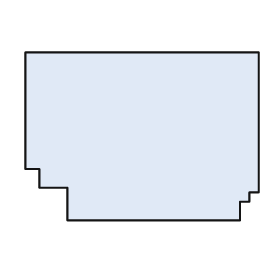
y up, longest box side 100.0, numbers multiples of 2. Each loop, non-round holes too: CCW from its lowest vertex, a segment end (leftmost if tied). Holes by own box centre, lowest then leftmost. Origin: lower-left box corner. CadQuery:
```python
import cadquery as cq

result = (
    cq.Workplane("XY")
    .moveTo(18.0, 0.0)
    .lineTo(92.0, 0.0)
    .lineTo(92.0, 8.0)
    .lineTo(96.0, 8.0)
    .lineTo(96.0, 12.0)
    .lineTo(100.0, 12.0)
    .lineTo(100.0, 72.0)
    .lineTo(0.0, 72.0)
    .lineTo(0.0, 22.0)
    .lineTo(6.0, 22.0)
    .lineTo(6.0, 14.0)
    .lineTo(18.0, 14.0)
    .close()
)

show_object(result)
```